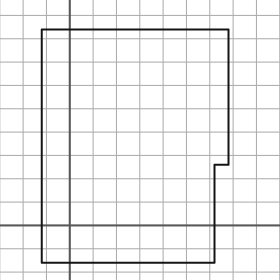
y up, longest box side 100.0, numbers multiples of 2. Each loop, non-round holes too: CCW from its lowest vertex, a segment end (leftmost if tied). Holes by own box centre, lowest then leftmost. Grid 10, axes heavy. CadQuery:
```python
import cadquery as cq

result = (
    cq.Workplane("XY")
    .moveTo(-12.0, -16.0)
    .lineTo(62.0, -16.0)
    .lineTo(62.0, 26.0)
    .lineTo(68.0, 26.0)
    .lineTo(68.0, 84.0)
    .lineTo(-12.0, 84.0)
    .close()
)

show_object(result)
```